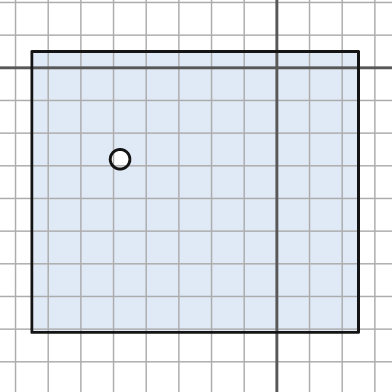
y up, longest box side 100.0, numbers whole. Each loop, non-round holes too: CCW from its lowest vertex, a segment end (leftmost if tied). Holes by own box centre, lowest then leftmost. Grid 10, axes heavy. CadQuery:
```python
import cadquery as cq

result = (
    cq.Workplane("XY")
    .moveTo(-75.0, -81.0)
    .lineTo(25.0, -81.0)
    .lineTo(25.0, 5.0)
    .lineTo(-75.0, 5.0)
    .close()
    .moveTo(-48.0, -28.0)
    .circle(3.0)
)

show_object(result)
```